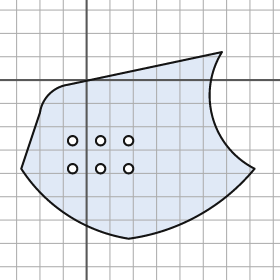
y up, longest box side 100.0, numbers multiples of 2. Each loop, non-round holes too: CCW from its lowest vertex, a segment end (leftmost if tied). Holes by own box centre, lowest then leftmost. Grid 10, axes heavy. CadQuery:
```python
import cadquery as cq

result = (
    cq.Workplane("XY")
    .moveTo(18.0, -68.0)
    .threePointArc((48.0, -58.0), (72.0, -38.0))
    .threePointArc((54.0, -16.0), (58.0, 12.0))
    .lineTo(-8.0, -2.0)
    .threePointArc((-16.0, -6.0), (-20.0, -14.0))
    .lineTo(-28.0, -38.0)
    .threePointArc((-8.0, -58.0), (18.0, -68.0))
    .close()
    .moveTo(-6.0, -38.0)
    .circle(2.0)
    .moveTo(6.0, -38.0)
    .circle(2.0)
    .moveTo(18.0, -38.0)
    .circle(2.0)
    .moveTo(-6.0, -26.0)
    .circle(2.0)
    .moveTo(6.0, -26.0)
    .circle(2.0)
    .moveTo(18.0, -26.0)
    .circle(2.0)
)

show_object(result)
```